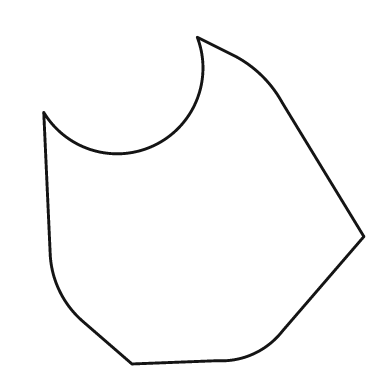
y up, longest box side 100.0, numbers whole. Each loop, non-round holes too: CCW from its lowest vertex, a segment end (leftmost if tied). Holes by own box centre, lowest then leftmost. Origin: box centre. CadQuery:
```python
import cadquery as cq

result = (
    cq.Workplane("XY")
    .moveTo(-22.0, -50.0)
    .lineTo(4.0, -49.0)
    .threePointArc((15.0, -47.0), (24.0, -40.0))
    .lineTo(49.0, -11.0)
    .lineTo(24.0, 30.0)
    .threePointArc((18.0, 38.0), (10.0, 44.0))
    .lineTo(-2.0, 50.0)
    .threePointArc((-15.0, 17.0), (-49.0, 27.0))
    .lineTo(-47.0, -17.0)
    .threePointArc((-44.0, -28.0), (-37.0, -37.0))
    .close()
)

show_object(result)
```